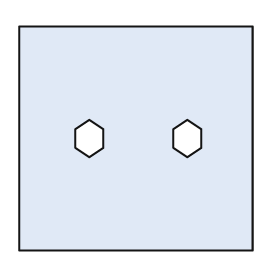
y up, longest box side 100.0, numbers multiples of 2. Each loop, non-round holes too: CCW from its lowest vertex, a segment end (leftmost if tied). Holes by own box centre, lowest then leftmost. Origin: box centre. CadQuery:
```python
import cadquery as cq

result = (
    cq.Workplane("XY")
    .moveTo(-50.0, -48.0)
    .lineTo(50.0, -48.0)
    .lineTo(50.0, 48.0)
    .lineTo(-50.0, 48.0)
    .close()
    .moveTo(-20.0, -8.0)
    .lineTo(-14.0, -4.0)
    .lineTo(-14.0, 4.0)
    .lineTo(-20.0, 8.0)
    .lineTo(-26.0, 4.0)
    .lineTo(-26.0, -4.0)
    .close()
    .moveTo(22.0, -8.0)
    .lineTo(28.0, -4.0)
    .lineTo(28.0, 4.0)
    .lineTo(22.0, 8.0)
    .lineTo(16.0, 4.0)
    .lineTo(16.0, -4.0)
    .close()
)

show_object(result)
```